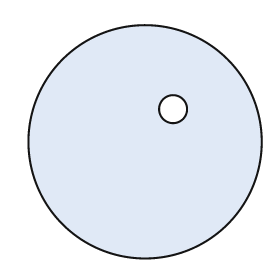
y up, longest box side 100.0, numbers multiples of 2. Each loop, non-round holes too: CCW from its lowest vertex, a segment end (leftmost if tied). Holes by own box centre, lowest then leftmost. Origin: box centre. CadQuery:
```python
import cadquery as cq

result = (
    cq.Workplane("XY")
    .moveTo(0.0, 0.0)
    .circle(50.0)
    .moveTo(12.0, 14.0)
    .circle(6.0)
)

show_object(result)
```